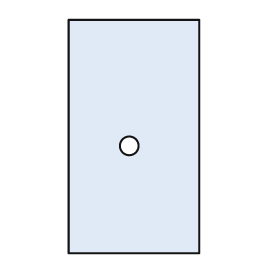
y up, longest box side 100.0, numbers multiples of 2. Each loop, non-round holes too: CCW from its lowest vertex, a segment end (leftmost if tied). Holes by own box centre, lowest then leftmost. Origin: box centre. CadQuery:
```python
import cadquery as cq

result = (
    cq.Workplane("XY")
    .moveTo(-28.0, -50.0)
    .lineTo(28.0, -50.0)
    .lineTo(28.0, 50.0)
    .lineTo(-28.0, 50.0)
    .close()
    .moveTo(-2.0, -4.0)
    .circle(4.0)
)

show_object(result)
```